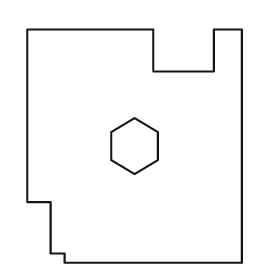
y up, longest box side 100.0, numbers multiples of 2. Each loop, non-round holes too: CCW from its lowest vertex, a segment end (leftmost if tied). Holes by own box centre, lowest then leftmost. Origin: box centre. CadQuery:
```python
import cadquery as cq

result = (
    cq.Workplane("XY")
    .moveTo(-30.0, -50.0)
    .lineTo(46.0, -50.0)
    .lineTo(46.0, 50.0)
    .lineTo(34.0, 50.0)
    .lineTo(34.0, 32.0)
    .lineTo(8.0, 32.0)
    .lineTo(8.0, 50.0)
    .lineTo(-46.0, 50.0)
    .lineTo(-46.0, -24.0)
    .lineTo(-36.0, -24.0)
    .lineTo(-36.0, -46.0)
    .lineTo(-30.0, -46.0)
    .close()
    .moveTo(0.0, -12.0)
    .lineTo(10.0, -6.0)
    .lineTo(10.0, 6.0)
    .lineTo(0.0, 12.0)
    .lineTo(-10.0, 6.0)
    .lineTo(-10.0, -6.0)
    .close()
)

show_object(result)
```